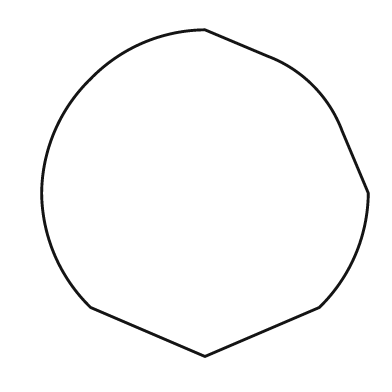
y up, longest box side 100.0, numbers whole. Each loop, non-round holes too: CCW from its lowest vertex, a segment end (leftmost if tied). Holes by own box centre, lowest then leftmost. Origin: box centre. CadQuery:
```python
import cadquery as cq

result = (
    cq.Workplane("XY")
    .moveTo(0.0, -50.0)
    .lineTo(35.0, -35.0)
    .threePointArc((46.0, -19.0), (50.0, 0.0))
    .lineTo(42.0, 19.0)
    .threePointArc((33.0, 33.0), (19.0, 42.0))
    .lineTo(0.0, 50.0)
    .threePointArc((-19.0, 46.0), (-35.0, 35.0))
    .threePointArc((-46.0, 19.0), (-50.0, 0.0))
    .threePointArc((-46.0, -19.0), (-35.0, -35.0))
    .close()
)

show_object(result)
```